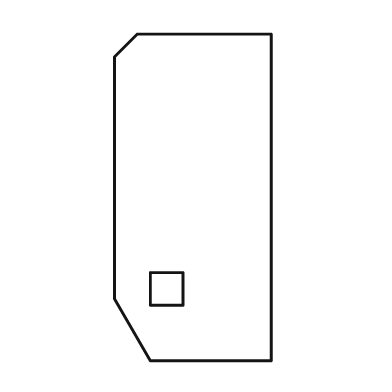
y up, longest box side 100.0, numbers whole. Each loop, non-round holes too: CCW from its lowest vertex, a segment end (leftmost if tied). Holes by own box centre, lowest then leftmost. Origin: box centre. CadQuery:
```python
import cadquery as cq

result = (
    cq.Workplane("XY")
    .moveTo(-13.0, -50.0)
    .lineTo(24.0, -50.0)
    .lineTo(24.0, 50.0)
    .lineTo(-17.0, 50.0)
    .lineTo(-24.0, 43.0)
    .lineTo(-24.0, -31.0)
    .close()
    .moveTo(-13.0, -33.0)
    .lineTo(-3.0, -33.0)
    .lineTo(-3.0, -23.0)
    .lineTo(-13.0, -23.0)
    .close()
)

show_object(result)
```